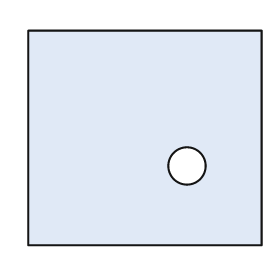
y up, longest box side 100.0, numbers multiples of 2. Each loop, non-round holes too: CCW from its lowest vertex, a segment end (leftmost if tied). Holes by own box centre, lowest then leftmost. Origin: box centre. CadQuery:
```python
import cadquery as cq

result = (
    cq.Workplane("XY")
    .moveTo(-50.0, -46.0)
    .lineTo(50.0, -46.0)
    .lineTo(50.0, 46.0)
    .lineTo(-50.0, 46.0)
    .close()
    .moveTo(18.0, -12.0)
    .circle(8.0)
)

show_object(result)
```